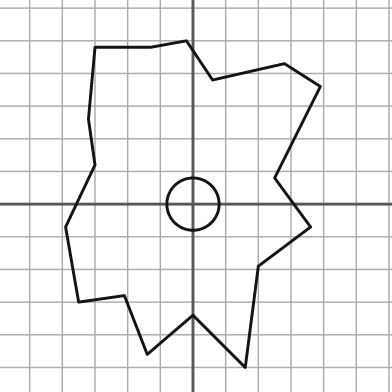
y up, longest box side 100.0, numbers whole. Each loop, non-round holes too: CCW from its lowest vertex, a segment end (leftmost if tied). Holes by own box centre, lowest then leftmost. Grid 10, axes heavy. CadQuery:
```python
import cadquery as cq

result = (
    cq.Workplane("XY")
    .moveTo(16.0, -50.0)
    .lineTo(20.0, -19.0)
    .lineTo(36.0, -7.0)
    .lineTo(25.0, 8.0)
    .lineTo(39.0, 36.0)
    .lineTo(28.0, 43.0)
    .lineTo(6.0, 38.0)
    .lineTo(-2.0, 50.0)
    .lineTo(-13.0, 48.0)
    .lineTo(-30.0, 48.0)
    .lineTo(-32.0, 26.0)
    .lineTo(-30.0, 12.0)
    .lineTo(-39.0, -7.0)
    .lineTo(-35.0, -30.0)
    .lineTo(-21.0, -28.0)
    .lineTo(-14.0, -46.0)
    .lineTo(0.0, -34.0)
    .close()
    .moveTo(0.0, 0.0)
    .circle(8.0)
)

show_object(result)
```